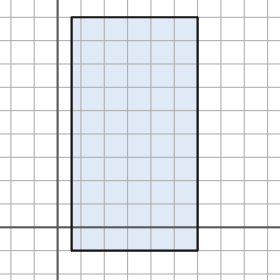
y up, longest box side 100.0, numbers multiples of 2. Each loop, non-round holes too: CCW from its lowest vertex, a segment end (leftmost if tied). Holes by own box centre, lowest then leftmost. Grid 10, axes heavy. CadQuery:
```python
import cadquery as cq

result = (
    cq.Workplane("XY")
    .moveTo(6.0, -10.0)
    .lineTo(60.0, -10.0)
    .lineTo(60.0, 90.0)
    .lineTo(6.0, 90.0)
    .close()
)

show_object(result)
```